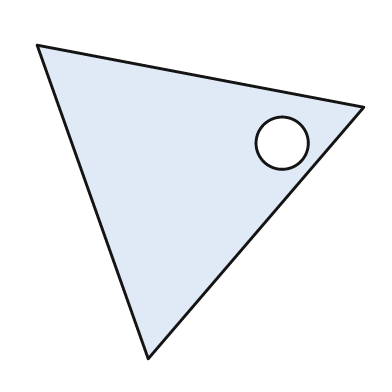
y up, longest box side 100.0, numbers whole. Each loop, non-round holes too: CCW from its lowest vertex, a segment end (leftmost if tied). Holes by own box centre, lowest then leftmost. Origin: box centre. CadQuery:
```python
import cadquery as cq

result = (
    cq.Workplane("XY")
    .moveTo(-16.0, -48.0)
    .lineTo(50.0, 29.0)
    .lineTo(-50.0, 48.0)
    .close()
    .moveTo(25.0, 18.0)
    .circle(8.0)
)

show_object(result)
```